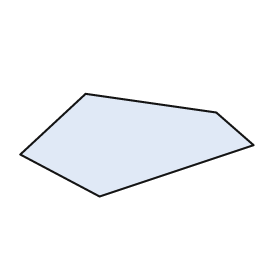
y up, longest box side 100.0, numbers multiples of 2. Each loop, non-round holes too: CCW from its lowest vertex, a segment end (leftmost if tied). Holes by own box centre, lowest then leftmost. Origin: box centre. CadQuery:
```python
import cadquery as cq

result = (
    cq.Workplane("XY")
    .moveTo(-16.0, -22.0)
    .lineTo(50.0, 0.0)
    .lineTo(34.0, 14.0)
    .lineTo(-22.0, 22.0)
    .lineTo(-50.0, -4.0)
    .close()
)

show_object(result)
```